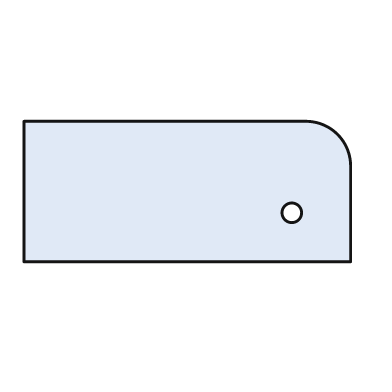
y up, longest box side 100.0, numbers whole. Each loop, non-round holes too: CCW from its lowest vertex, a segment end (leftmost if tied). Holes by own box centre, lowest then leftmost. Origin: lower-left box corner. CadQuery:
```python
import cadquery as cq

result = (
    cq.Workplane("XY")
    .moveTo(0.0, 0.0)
    .lineTo(100.0, 0.0)
    .lineTo(100.0, 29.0)
    .threePointArc((96.0, 39.0), (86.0, 43.0))
    .lineTo(0.0, 43.0)
    .close()
    .moveTo(82.0, 15.0)
    .circle(3.0)
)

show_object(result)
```